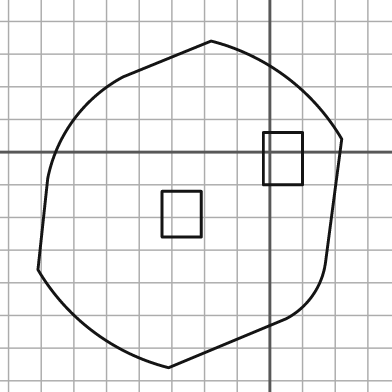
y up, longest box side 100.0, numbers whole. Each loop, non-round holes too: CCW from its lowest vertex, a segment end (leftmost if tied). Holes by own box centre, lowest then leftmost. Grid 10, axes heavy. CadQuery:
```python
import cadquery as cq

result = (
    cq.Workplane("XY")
    .moveTo(-31.0, -66.0)
    .lineTo(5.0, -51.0)
    .threePointArc((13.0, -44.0), (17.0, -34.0))
    .lineTo(22.0, 4.0)
    .threePointArc((5.0, 23.0), (-18.0, 34.0))
    .lineTo(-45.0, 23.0)
    .threePointArc((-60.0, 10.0), (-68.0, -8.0))
    .lineTo(-71.0, -36.0)
    .threePointArc((-54.0, -55.0), (-31.0, -66.0))
    .close()
    .moveTo(-33.0, -26.0)
    .lineTo(-21.0, -26.0)
    .lineTo(-21.0, -12.0)
    .lineTo(-33.0, -12.0)
    .close()
    .moveTo(-2.0, -10.0)
    .lineTo(10.0, -10.0)
    .lineTo(10.0, 6.0)
    .lineTo(-2.0, 6.0)
    .close()
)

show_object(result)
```